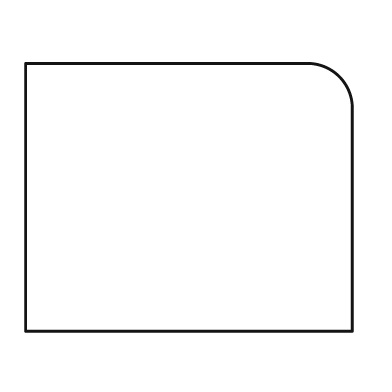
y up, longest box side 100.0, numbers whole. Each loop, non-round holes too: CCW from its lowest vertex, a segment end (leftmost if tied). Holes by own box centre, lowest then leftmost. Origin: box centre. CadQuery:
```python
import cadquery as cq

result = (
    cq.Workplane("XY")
    .moveTo(-50.0, -41.0)
    .lineTo(50.0, -41.0)
    .lineTo(50.0, 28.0)
    .threePointArc((46.0, 37.0), (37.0, 41.0))
    .lineTo(-50.0, 41.0)
    .close()
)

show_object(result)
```